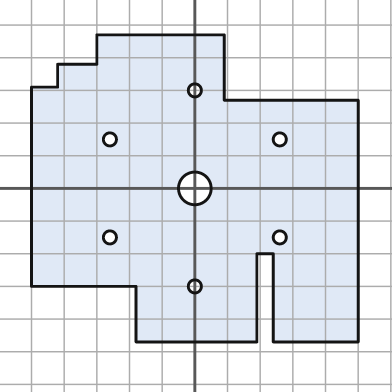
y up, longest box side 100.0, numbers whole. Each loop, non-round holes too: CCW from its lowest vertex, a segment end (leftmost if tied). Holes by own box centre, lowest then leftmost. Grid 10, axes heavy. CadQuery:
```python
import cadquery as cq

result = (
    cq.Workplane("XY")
    .moveTo(-18.0, -47.0)
    .lineTo(19.0, -47.0)
    .lineTo(19.0, -20.0)
    .lineTo(24.0, -20.0)
    .lineTo(24.0, -47.0)
    .lineTo(50.0, -47.0)
    .lineTo(50.0, 27.0)
    .lineTo(9.0, 27.0)
    .lineTo(9.0, 47.0)
    .lineTo(-30.0, 47.0)
    .lineTo(-30.0, 38.0)
    .lineTo(-42.0, 38.0)
    .lineTo(-42.0, 31.0)
    .lineTo(-50.0, 31.0)
    .lineTo(-50.0, -30.0)
    .lineTo(-18.0, -30.0)
    .close()
    .moveTo(0.0, -30.0)
    .circle(2.0)
    .moveTo(-26.0, -15.0)
    .circle(2.0)
    .moveTo(26.0, -15.0)
    .circle(2.0)
    .moveTo(0.0, 0.0)
    .circle(5.0)
    .moveTo(-26.0, 15.0)
    .circle(2.0)
    .moveTo(26.0, 15.0)
    .circle(2.0)
    .moveTo(0.0, 30.0)
    .circle(2.0)
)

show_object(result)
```